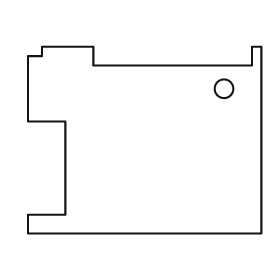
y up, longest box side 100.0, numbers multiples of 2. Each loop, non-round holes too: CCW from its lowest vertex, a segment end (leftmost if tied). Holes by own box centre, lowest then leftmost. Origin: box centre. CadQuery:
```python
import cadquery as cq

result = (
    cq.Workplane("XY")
    .moveTo(-50.0, -40.0)
    .lineTo(50.0, -40.0)
    .lineTo(50.0, 40.0)
    .lineTo(46.0, 40.0)
    .lineTo(46.0, 32.0)
    .lineTo(-22.0, 32.0)
    .lineTo(-22.0, 40.0)
    .lineTo(-44.0, 40.0)
    .lineTo(-44.0, 36.0)
    .lineTo(-50.0, 36.0)
    .lineTo(-50.0, 8.0)
    .lineTo(-34.0, 8.0)
    .lineTo(-34.0, -32.0)
    .lineTo(-50.0, -32.0)
    .close()
    .moveTo(34.0, 22.0)
    .circle(4.0)
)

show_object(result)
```